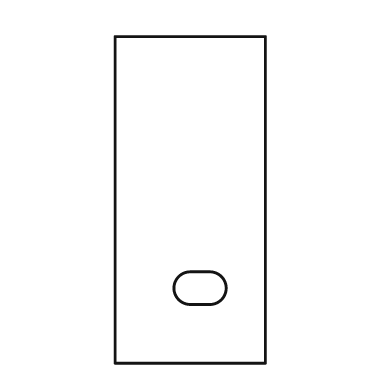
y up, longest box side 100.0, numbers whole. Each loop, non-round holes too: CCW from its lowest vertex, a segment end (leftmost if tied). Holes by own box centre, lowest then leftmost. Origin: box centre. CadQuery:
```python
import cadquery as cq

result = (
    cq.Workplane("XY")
    .moveTo(-23.0, -50.0)
    .lineTo(23.0, -50.0)
    .lineTo(23.0, 50.0)
    .lineTo(-23.0, 50.0)
    .close()
    .moveTo(0.0, -32.0)
    .lineTo(6.0, -32.0)
    .threePointArc((11.0, -27.0), (6.0, -22.0))
    .lineTo(0.0, -22.0)
    .threePointArc((-5.0, -27.0), (0.0, -32.0))
    .close()
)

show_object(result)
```